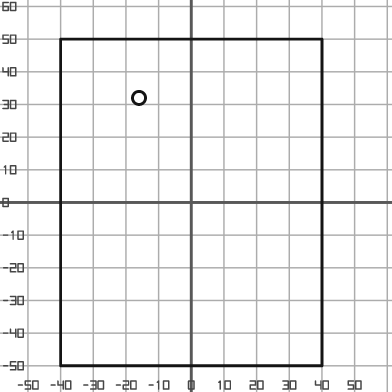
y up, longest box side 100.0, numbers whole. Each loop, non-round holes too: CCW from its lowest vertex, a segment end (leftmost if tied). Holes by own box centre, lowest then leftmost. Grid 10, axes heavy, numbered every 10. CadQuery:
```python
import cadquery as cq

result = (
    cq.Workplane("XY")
    .moveTo(-40.0, -50.0)
    .lineTo(40.0, -50.0)
    .lineTo(40.0, 50.0)
    .lineTo(-40.0, 50.0)
    .close()
    .moveTo(-16.0, 32.0)
    .circle(2.0)
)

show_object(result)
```